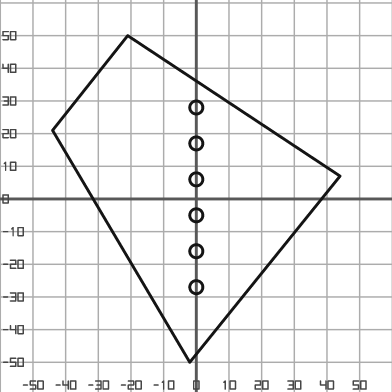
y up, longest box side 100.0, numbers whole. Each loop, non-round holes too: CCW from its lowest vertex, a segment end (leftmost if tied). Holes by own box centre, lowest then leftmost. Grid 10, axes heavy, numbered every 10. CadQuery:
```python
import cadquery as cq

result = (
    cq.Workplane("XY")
    .moveTo(-2.0, -50.0)
    .lineTo(44.0, 7.0)
    .lineTo(-21.0, 50.0)
    .lineTo(-44.0, 21.0)
    .close()
    .moveTo(0.0, -27.0)
    .circle(2.0)
    .moveTo(0.0, -16.0)
    .circle(2.0)
    .moveTo(0.0, -5.0)
    .circle(2.0)
    .moveTo(0.0, 6.0)
    .circle(2.0)
    .moveTo(0.0, 17.0)
    .circle(2.0)
    .moveTo(0.0, 28.0)
    .circle(2.0)
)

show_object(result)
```